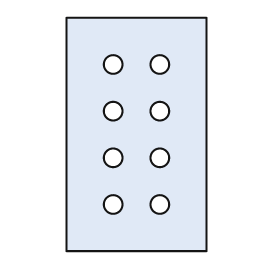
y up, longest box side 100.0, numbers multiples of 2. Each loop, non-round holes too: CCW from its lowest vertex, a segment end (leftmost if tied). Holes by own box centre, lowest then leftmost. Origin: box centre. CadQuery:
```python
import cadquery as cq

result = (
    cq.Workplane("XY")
    .moveTo(-30.0, -50.0)
    .lineTo(30.0, -50.0)
    .lineTo(30.0, 50.0)
    .lineTo(-30.0, 50.0)
    .close()
    .moveTo(-10.0, -30.0)
    .circle(4.0)
    .moveTo(10.0, -30.0)
    .circle(4.0)
    .moveTo(-10.0, -10.0)
    .circle(4.0)
    .moveTo(10.0, -10.0)
    .circle(4.0)
    .moveTo(-10.0, 10.0)
    .circle(4.0)
    .moveTo(10.0, 10.0)
    .circle(4.0)
    .moveTo(-10.0, 30.0)
    .circle(4.0)
    .moveTo(10.0, 30.0)
    .circle(4.0)
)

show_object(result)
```